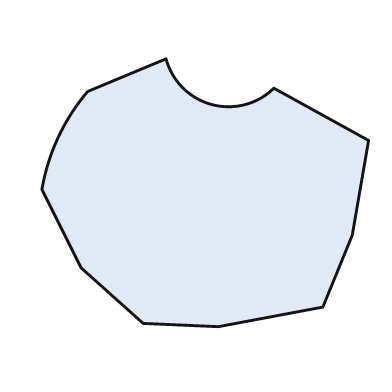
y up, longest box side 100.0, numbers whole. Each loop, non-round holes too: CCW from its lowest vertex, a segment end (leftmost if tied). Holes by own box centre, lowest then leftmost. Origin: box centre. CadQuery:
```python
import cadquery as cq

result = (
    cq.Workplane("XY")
    .moveTo(4.0, -41.0)
    .lineTo(36.0, -35.0)
    .lineTo(45.0, -13.0)
    .lineTo(50.0, 16.0)
    .lineTo(21.0, 32.0)
    .threePointArc((2.0, 27.0), (-12.0, 41.0))
    .lineTo(-36.0, 31.0)
    .threePointArc((-45.0, 17.0), (-50.0, 1.0))
    .lineTo(-38.0, -23.0)
    .lineTo(-19.0, -40.0)
    .close()
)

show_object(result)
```